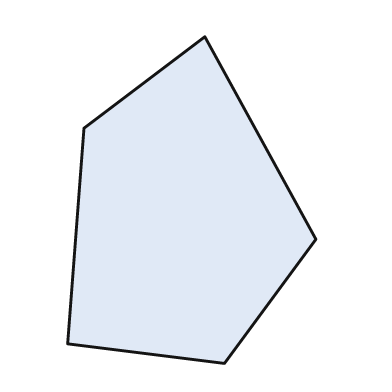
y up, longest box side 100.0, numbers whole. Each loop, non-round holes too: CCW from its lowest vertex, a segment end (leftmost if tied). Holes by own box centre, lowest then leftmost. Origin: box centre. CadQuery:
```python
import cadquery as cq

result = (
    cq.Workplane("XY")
    .moveTo(10.0, -50.0)
    .lineTo(38.0, -12.0)
    .lineTo(4.0, 50.0)
    .lineTo(-33.0, 22.0)
    .lineTo(-38.0, -44.0)
    .close()
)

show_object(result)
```